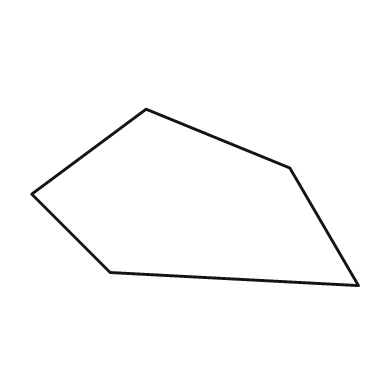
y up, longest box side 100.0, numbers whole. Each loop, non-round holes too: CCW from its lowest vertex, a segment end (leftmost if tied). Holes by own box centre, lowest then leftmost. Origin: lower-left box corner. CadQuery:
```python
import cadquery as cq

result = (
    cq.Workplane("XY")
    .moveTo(100.0, 0.0)
    .lineTo(79.0, 36.0)
    .lineTo(35.0, 54.0)
    .lineTo(0.0, 28.0)
    .lineTo(24.0, 4.0)
    .close()
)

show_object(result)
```